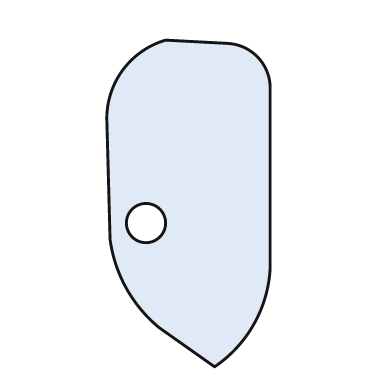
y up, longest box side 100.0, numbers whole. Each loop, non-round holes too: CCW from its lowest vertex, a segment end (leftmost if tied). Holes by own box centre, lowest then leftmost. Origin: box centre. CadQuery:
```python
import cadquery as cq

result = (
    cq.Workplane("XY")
    .moveTo(8.0, -50.0)
    .threePointArc((20.0, -37.0), (25.0, -20.0))
    .lineTo(25.0, 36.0)
    .threePointArc((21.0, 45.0), (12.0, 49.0))
    .lineTo(-7.0, 50.0)
    .threePointArc((-20.0, 41.0), (-25.0, 26.0))
    .lineTo(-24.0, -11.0)
    .threePointArc((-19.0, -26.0), (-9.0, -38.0))
    .close()
    .moveTo(-13.0, -6.0)
    .circle(6.0)
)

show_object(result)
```